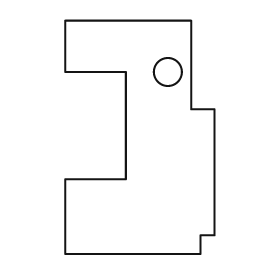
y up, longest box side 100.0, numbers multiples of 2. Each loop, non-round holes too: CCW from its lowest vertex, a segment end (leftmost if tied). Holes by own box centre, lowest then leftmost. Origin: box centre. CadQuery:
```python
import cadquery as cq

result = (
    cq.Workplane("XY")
    .moveTo(-32.0, -50.0)
    .lineTo(26.0, -50.0)
    .lineTo(26.0, -42.0)
    .lineTo(32.0, -42.0)
    .lineTo(32.0, 12.0)
    .lineTo(22.0, 12.0)
    .lineTo(22.0, 50.0)
    .lineTo(-32.0, 50.0)
    .lineTo(-32.0, 28.0)
    .lineTo(-6.0, 28.0)
    .lineTo(-6.0, -18.0)
    .lineTo(-32.0, -18.0)
    .close()
    .moveTo(12.0, 28.0)
    .circle(6.0)
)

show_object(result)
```